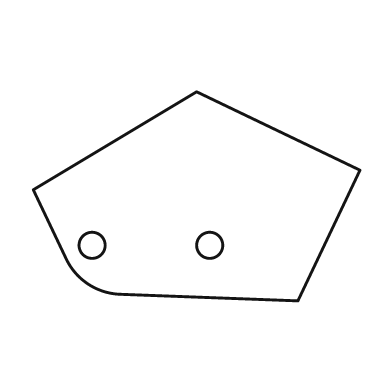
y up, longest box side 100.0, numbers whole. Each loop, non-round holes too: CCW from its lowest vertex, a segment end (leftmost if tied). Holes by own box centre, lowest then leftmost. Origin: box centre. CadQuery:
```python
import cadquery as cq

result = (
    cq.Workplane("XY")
    .moveTo(31.0, -32.0)
    .lineTo(50.0, 8.0)
    .lineTo(0.0, 32.0)
    .lineTo(-50.0, 2.0)
    .lineTo(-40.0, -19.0)
    .threePointArc((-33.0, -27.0), (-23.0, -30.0))
    .close()
    .moveTo(-32.0, -15.0)
    .circle(4.0)
    .moveTo(4.0, -15.0)
    .circle(4.0)
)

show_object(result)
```